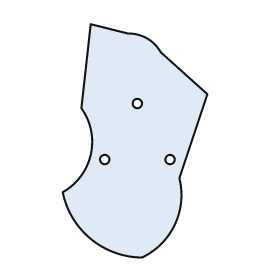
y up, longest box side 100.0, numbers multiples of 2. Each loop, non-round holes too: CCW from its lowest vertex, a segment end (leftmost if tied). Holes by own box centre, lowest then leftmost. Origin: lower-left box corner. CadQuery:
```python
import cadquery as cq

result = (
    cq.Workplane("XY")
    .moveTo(34.0, 0.0)
    .threePointArc((48.0, 14.0), (50.0, 34.0))
    .lineTo(62.0, 70.0)
    .lineTo(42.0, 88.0)
    .threePointArc((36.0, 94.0), (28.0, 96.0))
    .lineTo(12.0, 100.0)
    .lineTo(8.0, 64.0)
    .threePointArc((12.0, 44.0), (0.0, 28.0))
    .threePointArc((12.0, 8.0), (34.0, 0.0))
    .close()
    .moveTo(18.0, 42.0)
    .circle(2.0)
    .moveTo(46.0, 42.0)
    .circle(2.0)
    .moveTo(32.0, 66.0)
    .circle(2.0)
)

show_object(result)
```